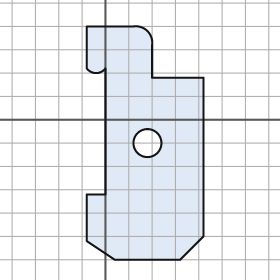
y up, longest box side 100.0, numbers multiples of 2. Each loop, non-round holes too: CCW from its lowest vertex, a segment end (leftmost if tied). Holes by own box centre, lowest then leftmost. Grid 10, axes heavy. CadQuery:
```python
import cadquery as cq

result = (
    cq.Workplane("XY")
    .moveTo(4.0, -60.0)
    .lineTo(32.0, -60.0)
    .lineTo(42.0, -50.0)
    .lineTo(42.0, 18.0)
    .lineTo(20.0, 18.0)
    .lineTo(20.0, 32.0)
    .threePointArc((18.0, 38.0), (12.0, 40.0))
    .lineTo(-8.0, 40.0)
    .lineTo(-8.0, 22.0)
    .threePointArc((-4.0, 20.0), (0.0, 22.0))
    .lineTo(0.0, -32.0)
    .lineTo(-8.0, -32.0)
    .lineTo(-8.0, -52.0)
    .close()
    .moveTo(18.0, -10.0)
    .circle(6.0)
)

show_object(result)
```